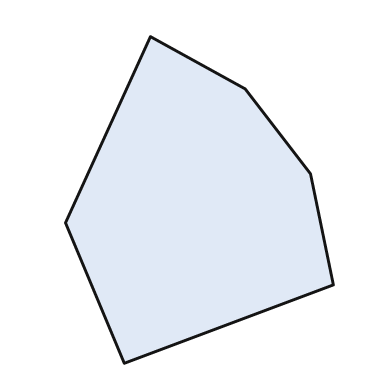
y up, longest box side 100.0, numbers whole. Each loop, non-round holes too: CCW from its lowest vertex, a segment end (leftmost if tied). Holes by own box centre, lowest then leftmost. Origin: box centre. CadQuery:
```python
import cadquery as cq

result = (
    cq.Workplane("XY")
    .moveTo(-23.0, -50.0)
    .lineTo(41.0, -26.0)
    .lineTo(34.0, 8.0)
    .lineTo(14.0, 34.0)
    .lineTo(-15.0, 50.0)
    .lineTo(-41.0, -7.0)
    .close()
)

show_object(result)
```